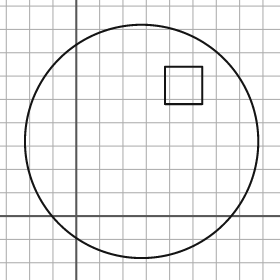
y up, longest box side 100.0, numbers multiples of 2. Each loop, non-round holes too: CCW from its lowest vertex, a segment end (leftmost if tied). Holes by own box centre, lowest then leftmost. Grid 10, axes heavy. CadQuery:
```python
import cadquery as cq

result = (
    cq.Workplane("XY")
    .moveTo(28.0, 32.0)
    .circle(50.0)
    .moveTo(38.0, 48.0)
    .lineTo(54.0, 48.0)
    .lineTo(54.0, 64.0)
    .lineTo(38.0, 64.0)
    .close()
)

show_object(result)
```